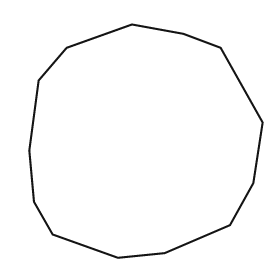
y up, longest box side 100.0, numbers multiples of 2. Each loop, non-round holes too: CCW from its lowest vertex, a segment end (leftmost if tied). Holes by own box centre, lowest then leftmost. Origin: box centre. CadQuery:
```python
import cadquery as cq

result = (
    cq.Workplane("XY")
    .moveTo(-12.0, -50.0)
    .lineTo(8.0, -48.0)
    .lineTo(36.0, -36.0)
    .lineTo(46.0, -18.0)
    .lineTo(50.0, 8.0)
    .lineTo(32.0, 40.0)
    .lineTo(16.0, 46.0)
    .lineTo(-6.0, 50.0)
    .lineTo(-34.0, 40.0)
    .lineTo(-46.0, 26.0)
    .lineTo(-50.0, -4.0)
    .lineTo(-48.0, -26.0)
    .lineTo(-40.0, -40.0)
    .close()
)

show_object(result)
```